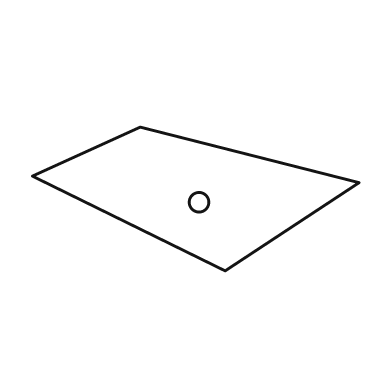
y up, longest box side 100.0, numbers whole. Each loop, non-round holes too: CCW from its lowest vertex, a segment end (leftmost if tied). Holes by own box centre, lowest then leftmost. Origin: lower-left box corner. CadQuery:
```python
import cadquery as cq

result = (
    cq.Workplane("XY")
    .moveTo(59.0, 0.0)
    .lineTo(100.0, 27.0)
    .lineTo(33.0, 44.0)
    .lineTo(0.0, 29.0)
    .close()
    .moveTo(51.0, 21.0)
    .circle(3.0)
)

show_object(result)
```